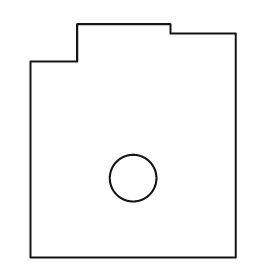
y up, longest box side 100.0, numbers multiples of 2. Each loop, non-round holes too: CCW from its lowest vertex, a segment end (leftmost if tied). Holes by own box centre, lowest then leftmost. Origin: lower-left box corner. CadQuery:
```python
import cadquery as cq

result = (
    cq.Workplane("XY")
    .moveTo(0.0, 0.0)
    .lineTo(88.0, 0.0)
    .lineTo(88.0, 96.0)
    .lineTo(60.0, 96.0)
    .lineTo(60.0, 100.0)
    .lineTo(20.0, 100.0)
    .lineTo(20.0, 84.0)
    .lineTo(0.0, 84.0)
    .close()
    .moveTo(44.0, 34.0)
    .circle(10.0)
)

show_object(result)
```